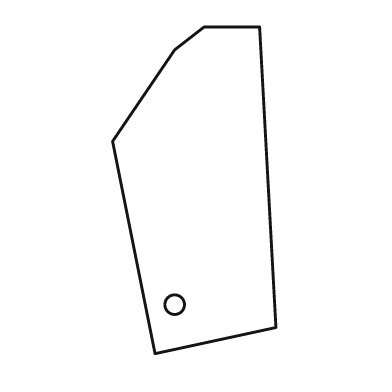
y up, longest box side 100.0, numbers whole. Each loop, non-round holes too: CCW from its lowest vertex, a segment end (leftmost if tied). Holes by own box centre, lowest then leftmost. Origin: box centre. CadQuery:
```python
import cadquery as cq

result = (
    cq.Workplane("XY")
    .moveTo(-12.0, -50.0)
    .lineTo(25.0, -42.0)
    .lineTo(20.0, 50.0)
    .lineTo(3.0, 50.0)
    .lineTo(-6.0, 43.0)
    .lineTo(-25.0, 15.0)
    .close()
    .moveTo(-6.0, -35.0)
    .circle(3.0)
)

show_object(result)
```